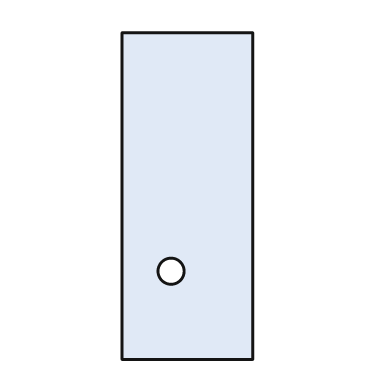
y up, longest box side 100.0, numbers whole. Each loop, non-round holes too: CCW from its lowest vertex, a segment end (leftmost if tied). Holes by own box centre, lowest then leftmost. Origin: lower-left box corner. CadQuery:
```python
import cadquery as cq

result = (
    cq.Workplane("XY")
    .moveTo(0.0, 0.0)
    .lineTo(40.0, 0.0)
    .lineTo(40.0, 100.0)
    .lineTo(0.0, 100.0)
    .close()
    .moveTo(15.0, 27.0)
    .circle(4.0)
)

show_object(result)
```